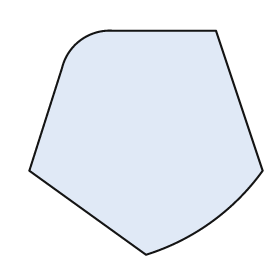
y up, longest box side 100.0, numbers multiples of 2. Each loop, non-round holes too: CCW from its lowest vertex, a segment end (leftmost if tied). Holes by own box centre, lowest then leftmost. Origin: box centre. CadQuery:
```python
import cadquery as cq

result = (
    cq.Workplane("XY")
    .moveTo(0.0, -48.0)
    .threePointArc((28.0, -34.0), (50.0, -12.0))
    .lineTo(30.0, 48.0)
    .lineTo(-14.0, 48.0)
    .threePointArc((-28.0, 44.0), (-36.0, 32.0))
    .lineTo(-50.0, -12.0)
    .close()
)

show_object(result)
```